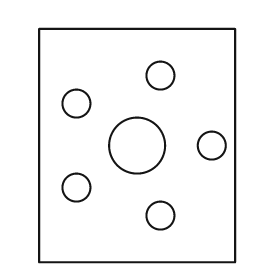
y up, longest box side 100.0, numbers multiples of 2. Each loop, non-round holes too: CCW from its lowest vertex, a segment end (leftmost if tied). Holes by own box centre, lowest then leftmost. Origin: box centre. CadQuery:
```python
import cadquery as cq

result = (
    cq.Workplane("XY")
    .moveTo(-42.0, -50.0)
    .lineTo(42.0, -50.0)
    .lineTo(42.0, 50.0)
    .lineTo(-42.0, 50.0)
    .close()
    .moveTo(10.0, -30.0)
    .circle(6.0)
    .moveTo(-26.0, -18.0)
    .circle(6.0)
    .moveTo(0.0, 0.0)
    .circle(12.0)
    .moveTo(32.0, 0.0)
    .circle(6.0)
    .moveTo(-26.0, 18.0)
    .circle(6.0)
    .moveTo(10.0, 30.0)
    .circle(6.0)
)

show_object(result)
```